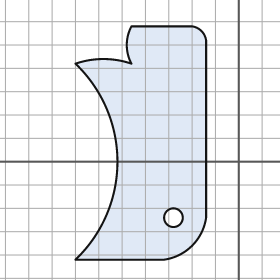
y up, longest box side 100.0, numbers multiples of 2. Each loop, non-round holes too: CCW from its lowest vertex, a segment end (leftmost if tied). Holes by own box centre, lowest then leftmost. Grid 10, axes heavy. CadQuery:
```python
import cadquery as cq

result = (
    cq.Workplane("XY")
    .moveTo(-70.0, -42.0)
    .lineTo(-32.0, -42.0)
    .threePointArc((-20.0, -36.0), (-14.0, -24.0))
    .lineTo(-14.0, 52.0)
    .threePointArc((-16.0, 56.0), (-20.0, 58.0))
    .lineTo(-46.0, 58.0)
    .threePointArc((-48.0, 50.0), (-46.0, 42.0))
    .threePointArc((-58.0, 44.0), (-70.0, 42.0))
    .threePointArc((-52.0, 0.0), (-70.0, -42.0))
    .close()
    .moveTo(-28.0, -24.0)
    .circle(4.0)
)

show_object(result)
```